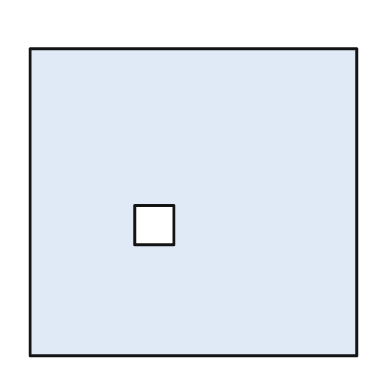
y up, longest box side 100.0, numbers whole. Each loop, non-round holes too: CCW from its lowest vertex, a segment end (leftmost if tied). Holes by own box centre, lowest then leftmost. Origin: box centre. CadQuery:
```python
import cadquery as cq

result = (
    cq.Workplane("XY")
    .moveTo(-50.0, -47.0)
    .lineTo(50.0, -47.0)
    .lineTo(50.0, 47.0)
    .lineTo(-50.0, 47.0)
    .close()
    .moveTo(-18.0, -13.0)
    .lineTo(-6.0, -13.0)
    .lineTo(-6.0, -1.0)
    .lineTo(-18.0, -1.0)
    .close()
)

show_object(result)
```